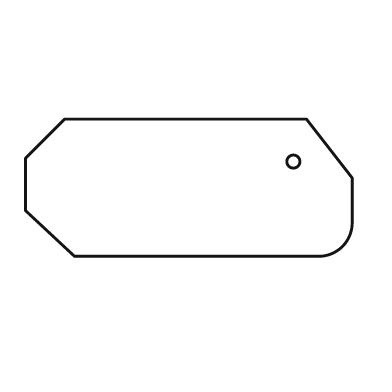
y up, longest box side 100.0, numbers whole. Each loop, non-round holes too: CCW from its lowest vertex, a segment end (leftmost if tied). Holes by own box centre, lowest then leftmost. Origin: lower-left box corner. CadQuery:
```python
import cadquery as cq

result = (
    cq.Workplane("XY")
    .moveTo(15.0, 0.0)
    .lineTo(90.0, 0.0)
    .threePointArc((97.0, 3.0), (100.0, 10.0))
    .lineTo(100.0, 24.0)
    .lineTo(86.0, 42.0)
    .lineTo(12.0, 42.0)
    .lineTo(0.0, 30.0)
    .lineTo(0.0, 14.0)
    .close()
    .moveTo(82.0, 29.0)
    .circle(2.0)
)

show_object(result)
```